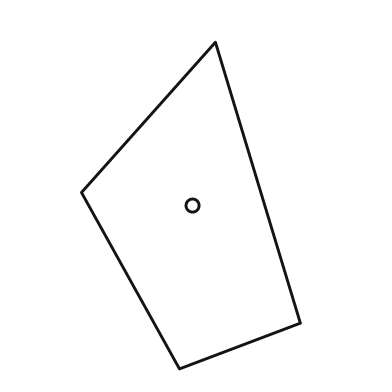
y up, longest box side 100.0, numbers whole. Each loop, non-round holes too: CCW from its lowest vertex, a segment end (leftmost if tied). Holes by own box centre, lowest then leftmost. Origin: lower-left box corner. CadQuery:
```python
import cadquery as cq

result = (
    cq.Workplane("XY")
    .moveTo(30.0, 0.0)
    .lineTo(67.0, 14.0)
    .lineTo(41.0, 100.0)
    .lineTo(0.0, 54.0)
    .close()
    .moveTo(34.0, 50.0)
    .circle(2.0)
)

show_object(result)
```